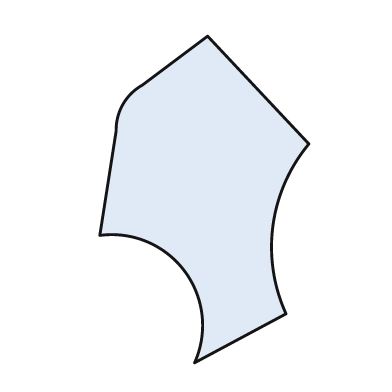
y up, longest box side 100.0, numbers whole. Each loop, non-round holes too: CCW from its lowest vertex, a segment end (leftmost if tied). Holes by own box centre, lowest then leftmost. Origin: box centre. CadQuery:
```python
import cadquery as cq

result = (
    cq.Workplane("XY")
    .moveTo(-3.0, -50.0)
    .lineTo(25.0, -35.0)
    .threePointArc((21.0, -8.0), (32.0, 17.0))
    .lineTo(1.0, 50.0)
    .lineTo(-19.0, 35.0)
    .threePointArc((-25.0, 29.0), (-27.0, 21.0))
    .lineTo(-32.0, -11.0)
    .threePointArc((-6.0, -22.0), (-3.0, -50.0))
    .close()
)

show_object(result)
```